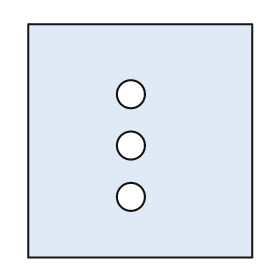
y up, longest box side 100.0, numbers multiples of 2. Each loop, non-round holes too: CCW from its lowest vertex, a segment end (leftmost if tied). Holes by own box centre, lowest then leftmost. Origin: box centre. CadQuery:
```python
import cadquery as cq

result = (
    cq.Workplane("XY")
    .moveTo(-48.0, -50.0)
    .lineTo(48.0, -50.0)
    .lineTo(48.0, 50.0)
    .lineTo(-48.0, 50.0)
    .close()
    .moveTo(-4.0, -24.0)
    .circle(6.0)
    .moveTo(-4.0, -2.0)
    .circle(6.0)
    .moveTo(-4.0, 20.0)
    .circle(6.0)
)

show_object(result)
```